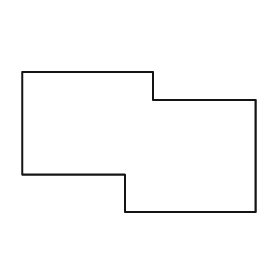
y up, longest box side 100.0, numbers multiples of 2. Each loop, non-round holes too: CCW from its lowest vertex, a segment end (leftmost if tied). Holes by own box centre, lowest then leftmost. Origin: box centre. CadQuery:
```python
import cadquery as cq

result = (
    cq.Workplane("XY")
    .moveTo(-6.0, -30.0)
    .lineTo(50.0, -30.0)
    .lineTo(50.0, 18.0)
    .lineTo(6.0, 18.0)
    .lineTo(6.0, 30.0)
    .lineTo(-50.0, 30.0)
    .lineTo(-50.0, -14.0)
    .lineTo(-6.0, -14.0)
    .close()
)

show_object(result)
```